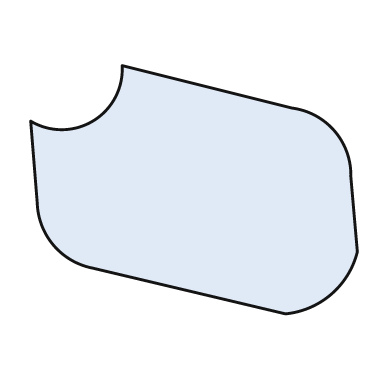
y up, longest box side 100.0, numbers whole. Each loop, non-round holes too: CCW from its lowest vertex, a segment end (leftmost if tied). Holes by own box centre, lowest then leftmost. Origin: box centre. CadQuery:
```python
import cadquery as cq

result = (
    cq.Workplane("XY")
    .moveTo(28.0, -38.0)
    .threePointArc((42.0, -32.0), (50.0, -19.0))
    .lineTo(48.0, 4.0)
    .threePointArc((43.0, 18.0), (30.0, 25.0))
    .lineTo(-22.0, 38.0)
    .threePointArc((-31.0, 21.0), (-50.0, 21.0))
    .lineTo(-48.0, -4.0)
    .threePointArc((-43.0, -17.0), (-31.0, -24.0))
    .close()
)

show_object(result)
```